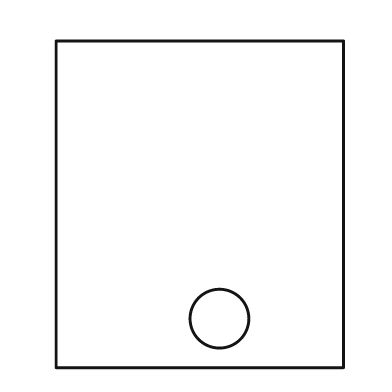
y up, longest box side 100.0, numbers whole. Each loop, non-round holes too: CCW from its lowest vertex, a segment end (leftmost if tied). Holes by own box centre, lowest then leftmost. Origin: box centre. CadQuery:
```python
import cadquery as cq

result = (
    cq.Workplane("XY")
    .moveTo(-44.0, -50.0)
    .lineTo(44.0, -50.0)
    .lineTo(44.0, 50.0)
    .lineTo(-44.0, 50.0)
    .close()
    .moveTo(6.0, -35.0)
    .circle(9.0)
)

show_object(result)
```